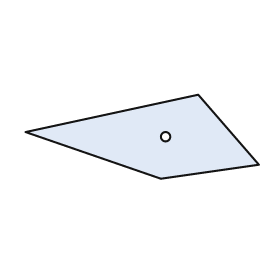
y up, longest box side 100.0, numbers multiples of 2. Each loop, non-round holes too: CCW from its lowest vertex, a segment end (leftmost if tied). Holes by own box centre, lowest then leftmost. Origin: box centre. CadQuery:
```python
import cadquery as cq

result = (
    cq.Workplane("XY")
    .moveTo(8.0, -18.0)
    .lineTo(50.0, -12.0)
    .lineTo(24.0, 18.0)
    .lineTo(-50.0, 2.0)
    .close()
    .moveTo(10.0, 0.0)
    .circle(2.0)
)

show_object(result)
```